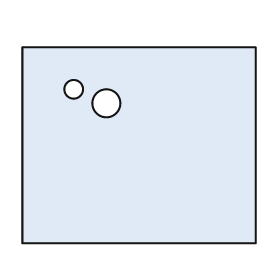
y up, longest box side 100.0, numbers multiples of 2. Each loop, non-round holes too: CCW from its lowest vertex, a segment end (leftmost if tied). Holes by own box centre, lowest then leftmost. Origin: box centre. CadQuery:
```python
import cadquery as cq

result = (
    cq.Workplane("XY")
    .moveTo(-50.0, -42.0)
    .lineTo(50.0, -42.0)
    .lineTo(50.0, 42.0)
    .lineTo(-50.0, 42.0)
    .close()
    .moveTo(-14.0, 18.0)
    .circle(6.0)
    .moveTo(-28.0, 24.0)
    .circle(4.0)
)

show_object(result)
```